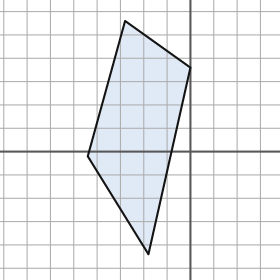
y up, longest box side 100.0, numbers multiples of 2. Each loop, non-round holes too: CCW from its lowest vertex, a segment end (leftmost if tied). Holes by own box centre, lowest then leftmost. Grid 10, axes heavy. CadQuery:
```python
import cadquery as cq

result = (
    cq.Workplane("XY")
    .moveTo(-18.0, -44.0)
    .lineTo(0.0, 36.0)
    .lineTo(-28.0, 56.0)
    .lineTo(-44.0, -2.0)
    .close()
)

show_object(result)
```